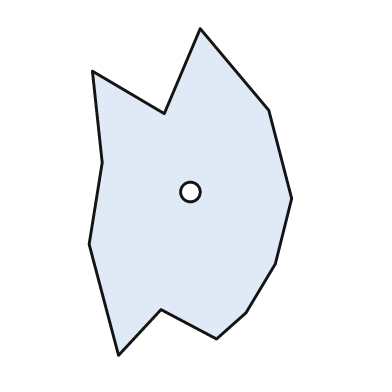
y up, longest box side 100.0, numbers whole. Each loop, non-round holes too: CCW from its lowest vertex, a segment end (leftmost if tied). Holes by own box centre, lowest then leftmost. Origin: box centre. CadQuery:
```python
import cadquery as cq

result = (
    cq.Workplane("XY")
    .moveTo(-22.0, -50.0)
    .lineTo(-9.0, -36.0)
    .lineTo(8.0, -45.0)
    .lineTo(17.0, -37.0)
    .lineTo(26.0, -22.0)
    .lineTo(31.0, -2.0)
    .lineTo(24.0, 25.0)
    .lineTo(3.0, 50.0)
    .lineTo(-8.0, 24.0)
    .lineTo(-30.0, 37.0)
    .lineTo(-27.0, 9.0)
    .lineTo(-31.0, -16.0)
    .close()
    .moveTo(0.0, 0.0)
    .circle(3.0)
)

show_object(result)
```